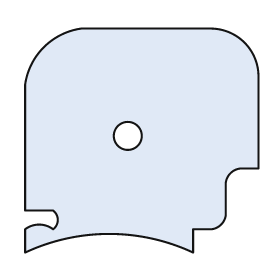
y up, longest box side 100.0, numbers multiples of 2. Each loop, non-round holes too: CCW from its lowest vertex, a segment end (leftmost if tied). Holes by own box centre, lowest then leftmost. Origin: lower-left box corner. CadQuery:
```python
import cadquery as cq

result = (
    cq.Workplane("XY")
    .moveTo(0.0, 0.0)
    .threePointArc((36.0, 8.0), (72.0, 0.0))
    .lineTo(72.0, 10.0)
    .lineTo(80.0, 10.0)
    .threePointArc((84.0, 12.0), (86.0, 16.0))
    .lineTo(86.0, 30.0)
    .threePointArc((88.0, 34.0), (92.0, 36.0))
    .lineTo(100.0, 36.0)
    .lineTo(100.0, 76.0)
    .threePointArc((94.0, 90.0), (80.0, 96.0))
    .lineTo(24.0, 96.0)
    .threePointArc((8.0, 88.0), (0.0, 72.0))
    .lineTo(0.0, 18.0)
    .lineTo(12.0, 18.0)
    .threePointArc((14.0, 14.0), (12.0, 10.0))
    .threePointArc((6.0, 12.0), (0.0, 10.0))
    .close()
    .moveTo(44.0, 50.0)
    .circle(6.0)
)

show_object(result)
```